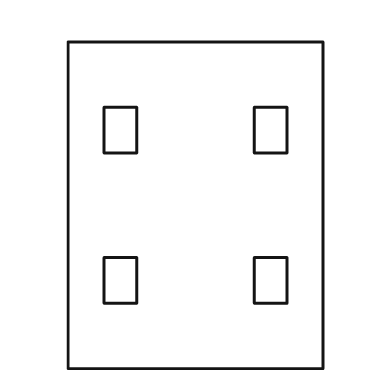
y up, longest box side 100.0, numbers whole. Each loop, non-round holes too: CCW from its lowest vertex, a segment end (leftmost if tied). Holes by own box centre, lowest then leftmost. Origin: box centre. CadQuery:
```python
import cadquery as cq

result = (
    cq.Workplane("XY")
    .moveTo(-39.0, -50.0)
    .lineTo(39.0, -50.0)
    .lineTo(39.0, 50.0)
    .lineTo(-39.0, 50.0)
    .close()
    .moveTo(-28.0, -30.0)
    .lineTo(-18.0, -30.0)
    .lineTo(-18.0, -16.0)
    .lineTo(-28.0, -16.0)
    .close()
    .moveTo(18.0, -30.0)
    .lineTo(28.0, -30.0)
    .lineTo(28.0, -16.0)
    .lineTo(18.0, -16.0)
    .close()
    .moveTo(-28.0, 16.0)
    .lineTo(-18.0, 16.0)
    .lineTo(-18.0, 30.0)
    .lineTo(-28.0, 30.0)
    .close()
    .moveTo(18.0, 16.0)
    .lineTo(28.0, 16.0)
    .lineTo(28.0, 30.0)
    .lineTo(18.0, 30.0)
    .close()
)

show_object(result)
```